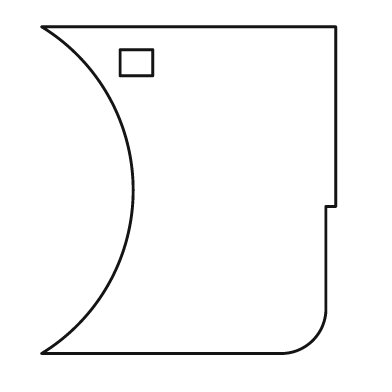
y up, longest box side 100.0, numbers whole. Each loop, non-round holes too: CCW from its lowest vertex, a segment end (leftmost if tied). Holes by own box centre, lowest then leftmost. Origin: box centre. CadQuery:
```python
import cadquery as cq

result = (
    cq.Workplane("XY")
    .moveTo(-45.0, -50.0)
    .lineTo(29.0, -50.0)
    .threePointArc((38.0, -46.0), (42.0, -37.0))
    .lineTo(42.0, -5.0)
    .lineTo(45.0, -5.0)
    .lineTo(45.0, 50.0)
    .lineTo(-45.0, 50.0)
    .threePointArc((-17.0, 0.0), (-45.0, -50.0))
    .close()
    .moveTo(-21.0, 35.0)
    .lineTo(-11.0, 35.0)
    .lineTo(-11.0, 43.0)
    .lineTo(-21.0, 43.0)
    .close()
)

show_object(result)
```